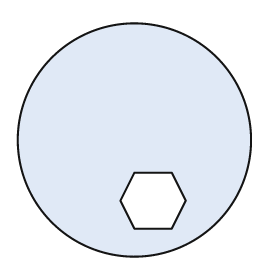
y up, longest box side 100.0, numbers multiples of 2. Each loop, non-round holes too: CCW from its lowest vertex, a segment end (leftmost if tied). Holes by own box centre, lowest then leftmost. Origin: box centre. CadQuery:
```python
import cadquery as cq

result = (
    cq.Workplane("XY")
    .moveTo(0.0, 0.0)
    .circle(50.0)
    .moveTo(0.0, -38.0)
    .lineTo(16.0, -38.0)
    .lineTo(22.0, -26.0)
    .lineTo(16.0, -14.0)
    .lineTo(0.0, -14.0)
    .lineTo(-6.0, -26.0)
    .close()
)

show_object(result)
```